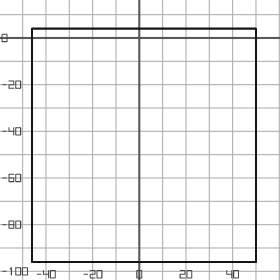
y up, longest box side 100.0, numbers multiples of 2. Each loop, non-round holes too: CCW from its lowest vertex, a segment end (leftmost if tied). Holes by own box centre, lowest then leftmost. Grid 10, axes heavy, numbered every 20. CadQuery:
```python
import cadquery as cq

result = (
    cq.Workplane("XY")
    .moveTo(-46.0, -96.0)
    .lineTo(50.0, -96.0)
    .lineTo(50.0, 4.0)
    .lineTo(-46.0, 4.0)
    .close()
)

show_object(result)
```